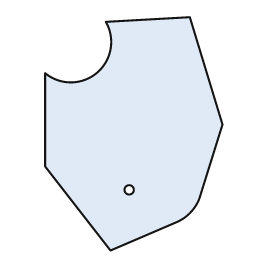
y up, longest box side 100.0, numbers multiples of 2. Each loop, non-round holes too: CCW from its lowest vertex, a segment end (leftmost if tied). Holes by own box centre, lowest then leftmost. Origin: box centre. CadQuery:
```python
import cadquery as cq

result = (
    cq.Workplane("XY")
    .moveTo(-10.0, -50.0)
    .lineTo(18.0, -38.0)
    .threePointArc((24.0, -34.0), (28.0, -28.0))
    .lineTo(38.0, 4.0)
    .lineTo(24.0, 50.0)
    .lineTo(-12.0, 48.0)
    .threePointArc((-16.0, 26.0), (-38.0, 26.0))
    .lineTo(-38.0, -14.0)
    .close()
    .moveTo(-2.0, -24.0)
    .circle(2.0)
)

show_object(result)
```